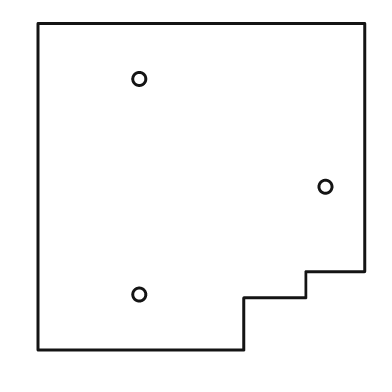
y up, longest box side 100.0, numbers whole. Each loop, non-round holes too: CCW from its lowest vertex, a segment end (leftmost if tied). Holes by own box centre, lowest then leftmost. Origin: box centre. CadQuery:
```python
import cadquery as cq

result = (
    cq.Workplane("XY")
    .moveTo(-50.0, -50.0)
    .lineTo(13.0, -50.0)
    .lineTo(13.0, -34.0)
    .lineTo(32.0, -34.0)
    .lineTo(32.0, -26.0)
    .lineTo(50.0, -26.0)
    .lineTo(50.0, 50.0)
    .lineTo(-50.0, 50.0)
    .close()
    .moveTo(-19.0, -33.0)
    .circle(2.0)
    .moveTo(38.0, 0.0)
    .circle(2.0)
    .moveTo(-19.0, 33.0)
    .circle(2.0)
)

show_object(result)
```